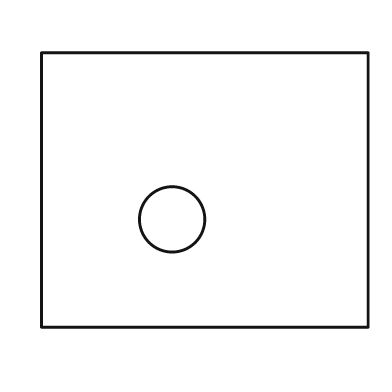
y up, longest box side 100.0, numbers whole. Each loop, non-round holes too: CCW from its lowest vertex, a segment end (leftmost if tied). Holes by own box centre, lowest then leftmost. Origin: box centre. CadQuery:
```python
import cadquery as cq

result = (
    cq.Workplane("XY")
    .moveTo(-50.0, -42.0)
    .lineTo(50.0, -42.0)
    .lineTo(50.0, 42.0)
    .lineTo(-50.0, 42.0)
    .close()
    .moveTo(-10.0, -9.0)
    .circle(10.0)
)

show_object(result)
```